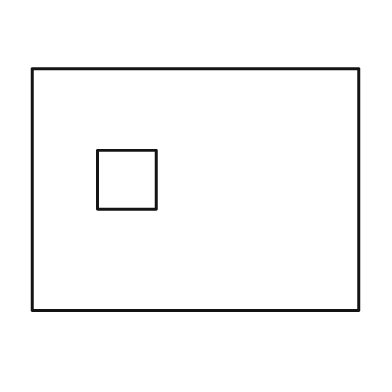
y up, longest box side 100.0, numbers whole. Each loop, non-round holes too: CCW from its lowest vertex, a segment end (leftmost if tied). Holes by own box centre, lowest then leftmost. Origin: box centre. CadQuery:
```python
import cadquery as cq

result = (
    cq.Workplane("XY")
    .moveTo(-50.0, -37.0)
    .lineTo(50.0, -37.0)
    .lineTo(50.0, 37.0)
    .lineTo(-50.0, 37.0)
    .close()
    .moveTo(-30.0, -6.0)
    .lineTo(-12.0, -6.0)
    .lineTo(-12.0, 12.0)
    .lineTo(-30.0, 12.0)
    .close()
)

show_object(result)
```